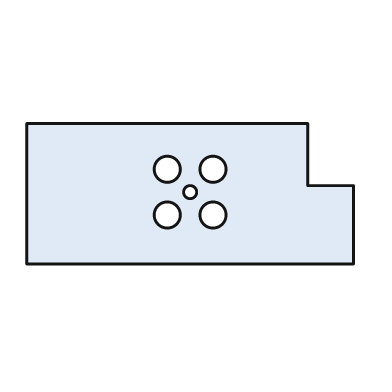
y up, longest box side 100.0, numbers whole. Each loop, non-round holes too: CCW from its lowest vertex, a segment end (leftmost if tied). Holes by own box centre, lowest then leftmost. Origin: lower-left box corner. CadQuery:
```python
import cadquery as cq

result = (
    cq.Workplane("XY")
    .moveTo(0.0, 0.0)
    .lineTo(100.0, 0.0)
    .lineTo(100.0, 24.0)
    .lineTo(86.0, 24.0)
    .lineTo(86.0, 43.0)
    .lineTo(0.0, 43.0)
    .close()
    .moveTo(43.0, 15.0)
    .circle(4.0)
    .moveTo(57.0, 15.0)
    .circle(4.0)
    .moveTo(50.0, 22.0)
    .circle(2.0)
    .moveTo(43.0, 29.0)
    .circle(4.0)
    .moveTo(57.0, 29.0)
    .circle(4.0)
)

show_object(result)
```